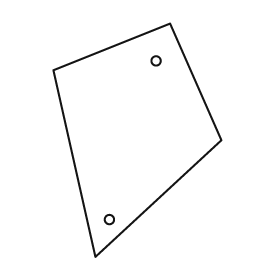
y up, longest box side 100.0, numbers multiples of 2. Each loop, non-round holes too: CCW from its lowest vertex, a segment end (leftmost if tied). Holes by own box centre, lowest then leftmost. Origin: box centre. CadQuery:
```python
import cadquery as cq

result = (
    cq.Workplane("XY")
    .moveTo(-18.0, -50.0)
    .lineTo(36.0, 0.0)
    .lineTo(14.0, 50.0)
    .lineTo(-36.0, 30.0)
    .close()
    .moveTo(-12.0, -34.0)
    .circle(2.0)
    .moveTo(8.0, 34.0)
    .circle(2.0)
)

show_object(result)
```